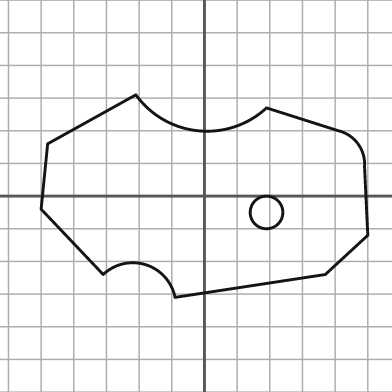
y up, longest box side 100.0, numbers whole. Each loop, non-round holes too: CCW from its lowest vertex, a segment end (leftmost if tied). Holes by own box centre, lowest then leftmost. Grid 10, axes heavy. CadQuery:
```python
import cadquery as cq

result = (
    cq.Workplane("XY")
    .moveTo(-9.0, -31.0)
    .lineTo(37.0, -24.0)
    .lineTo(50.0, -12.0)
    .lineTo(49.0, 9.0)
    .threePointArc((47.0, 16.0), (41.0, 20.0))
    .lineTo(19.0, 27.0)
    .threePointArc((-2.0, 20.0), (-21.0, 31.0))
    .lineTo(-48.0, 16.0)
    .lineTo(-50.0, -4.0)
    .lineTo(-31.0, -24.0)
    .threePointArc((-18.0, -21.0), (-9.0, -31.0))
    .close()
    .moveTo(19.0, -5.0)
    .circle(5.0)
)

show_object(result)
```